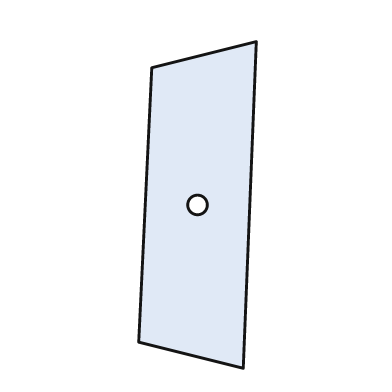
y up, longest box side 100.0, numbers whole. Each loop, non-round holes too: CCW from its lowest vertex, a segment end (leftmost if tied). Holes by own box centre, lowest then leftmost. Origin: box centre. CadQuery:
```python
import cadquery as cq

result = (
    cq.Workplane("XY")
    .moveTo(14.0, -50.0)
    .lineTo(18.0, 50.0)
    .lineTo(-14.0, 42.0)
    .lineTo(-18.0, -42.0)
    .close()
    .moveTo(0.0, 0.0)
    .circle(3.0)
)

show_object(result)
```